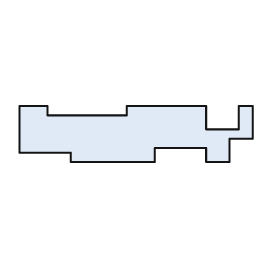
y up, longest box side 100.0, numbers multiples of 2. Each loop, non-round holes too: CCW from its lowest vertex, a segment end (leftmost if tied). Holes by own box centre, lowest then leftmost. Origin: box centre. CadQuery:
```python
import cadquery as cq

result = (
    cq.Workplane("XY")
    .moveTo(-28.0, -12.0)
    .lineTo(8.0, -12.0)
    .lineTo(8.0, -6.0)
    .lineTo(30.0, -6.0)
    .lineTo(30.0, -12.0)
    .lineTo(40.0, -12.0)
    .lineTo(40.0, -2.0)
    .lineTo(50.0, -2.0)
    .lineTo(50.0, 12.0)
    .lineTo(44.0, 12.0)
    .lineTo(44.0, 2.0)
    .lineTo(30.0, 2.0)
    .lineTo(30.0, 12.0)
    .lineTo(-4.0, 12.0)
    .lineTo(-4.0, 8.0)
    .lineTo(-38.0, 8.0)
    .lineTo(-38.0, 12.0)
    .lineTo(-50.0, 12.0)
    .lineTo(-50.0, -8.0)
    .lineTo(-28.0, -8.0)
    .close()
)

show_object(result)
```